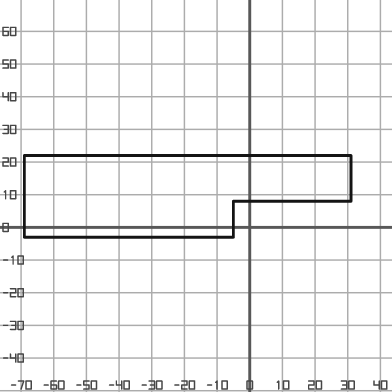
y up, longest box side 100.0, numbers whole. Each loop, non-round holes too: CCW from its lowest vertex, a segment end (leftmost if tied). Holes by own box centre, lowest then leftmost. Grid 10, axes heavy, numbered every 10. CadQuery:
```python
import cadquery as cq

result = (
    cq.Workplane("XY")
    .moveTo(-69.0, -3.0)
    .lineTo(-5.0, -3.0)
    .lineTo(-5.0, 8.0)
    .lineTo(31.0, 8.0)
    .lineTo(31.0, 22.0)
    .lineTo(-69.0, 22.0)
    .close()
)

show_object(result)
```